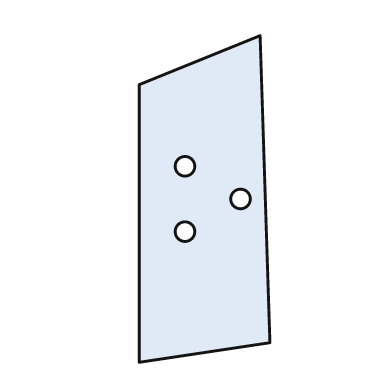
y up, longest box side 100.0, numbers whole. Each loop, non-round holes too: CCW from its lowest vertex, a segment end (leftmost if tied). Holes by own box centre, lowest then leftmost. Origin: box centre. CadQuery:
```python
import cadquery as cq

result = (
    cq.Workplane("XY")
    .moveTo(-20.0, -50.0)
    .lineTo(20.0, -44.0)
    .lineTo(17.0, 50.0)
    .lineTo(-20.0, 35.0)
    .close()
    .moveTo(-6.0, -10.0)
    .circle(3.0)
    .moveTo(11.0, 0.0)
    .circle(3.0)
    .moveTo(-6.0, 10.0)
    .circle(3.0)
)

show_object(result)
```